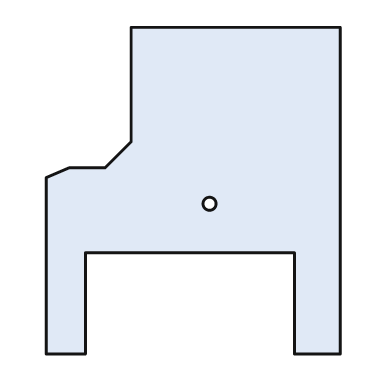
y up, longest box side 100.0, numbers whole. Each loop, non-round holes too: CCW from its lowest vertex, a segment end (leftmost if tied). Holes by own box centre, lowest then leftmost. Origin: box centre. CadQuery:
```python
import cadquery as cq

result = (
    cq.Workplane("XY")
    .moveTo(-45.0, -50.0)
    .lineTo(-33.0, -50.0)
    .lineTo(-33.0, -19.0)
    .lineTo(31.0, -19.0)
    .lineTo(31.0, -50.0)
    .lineTo(45.0, -50.0)
    .lineTo(45.0, 50.0)
    .lineTo(-19.0, 50.0)
    .lineTo(-19.0, 15.0)
    .lineTo(-27.0, 7.0)
    .lineTo(-38.0, 7.0)
    .lineTo(-45.0, 4.0)
    .close()
    .moveTo(5.0, -4.0)
    .circle(2.0)
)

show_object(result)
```